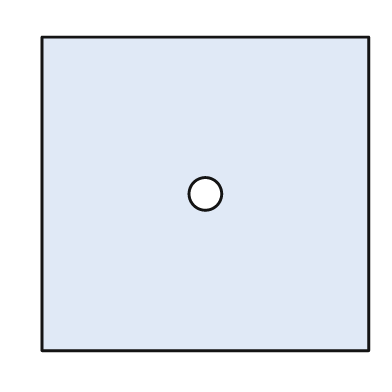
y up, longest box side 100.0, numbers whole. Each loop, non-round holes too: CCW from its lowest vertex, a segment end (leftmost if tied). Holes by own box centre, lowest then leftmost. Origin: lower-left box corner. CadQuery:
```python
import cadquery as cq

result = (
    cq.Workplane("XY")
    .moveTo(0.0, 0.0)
    .lineTo(100.0, 0.0)
    .lineTo(100.0, 96.0)
    .lineTo(0.0, 96.0)
    .close()
    .moveTo(50.0, 48.0)
    .circle(5.0)
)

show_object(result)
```